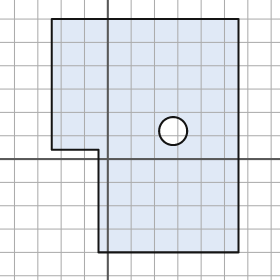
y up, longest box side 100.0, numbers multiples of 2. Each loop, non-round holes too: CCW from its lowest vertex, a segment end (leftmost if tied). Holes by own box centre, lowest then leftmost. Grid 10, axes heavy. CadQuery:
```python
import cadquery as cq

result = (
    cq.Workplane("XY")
    .moveTo(-4.0, -40.0)
    .lineTo(56.0, -40.0)
    .lineTo(56.0, 60.0)
    .lineTo(-24.0, 60.0)
    .lineTo(-24.0, 4.0)
    .lineTo(-4.0, 4.0)
    .close()
    .moveTo(28.0, 12.0)
    .circle(6.0)
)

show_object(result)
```